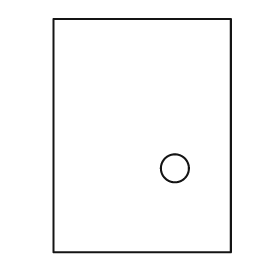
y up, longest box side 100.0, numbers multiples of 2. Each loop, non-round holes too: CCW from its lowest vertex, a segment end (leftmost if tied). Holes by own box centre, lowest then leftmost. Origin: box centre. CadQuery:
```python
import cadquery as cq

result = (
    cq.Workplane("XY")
    .moveTo(-38.0, -50.0)
    .lineTo(38.0, -50.0)
    .lineTo(38.0, 50.0)
    .lineTo(-38.0, 50.0)
    .close()
    .moveTo(14.0, -14.0)
    .circle(6.0)
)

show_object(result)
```